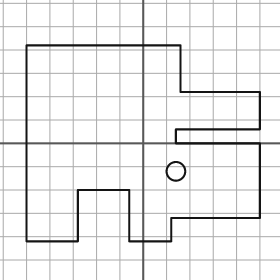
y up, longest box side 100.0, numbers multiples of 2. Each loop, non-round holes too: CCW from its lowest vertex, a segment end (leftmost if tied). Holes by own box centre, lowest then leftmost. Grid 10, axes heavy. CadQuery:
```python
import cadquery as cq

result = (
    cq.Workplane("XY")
    .moveTo(-50.0, -42.0)
    .lineTo(-28.0, -42.0)
    .lineTo(-28.0, -20.0)
    .lineTo(-6.0, -20.0)
    .lineTo(-6.0, -42.0)
    .lineTo(12.0, -42.0)
    .lineTo(12.0, -32.0)
    .lineTo(50.0, -32.0)
    .lineTo(50.0, 0.0)
    .lineTo(14.0, 0.0)
    .lineTo(14.0, 6.0)
    .lineTo(50.0, 6.0)
    .lineTo(50.0, 22.0)
    .lineTo(16.0, 22.0)
    .lineTo(16.0, 42.0)
    .lineTo(-50.0, 42.0)
    .close()
    .moveTo(14.0, -12.0)
    .circle(4.0)
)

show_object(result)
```